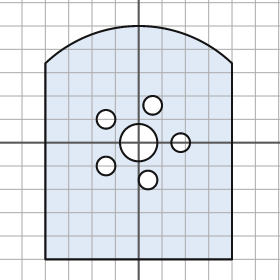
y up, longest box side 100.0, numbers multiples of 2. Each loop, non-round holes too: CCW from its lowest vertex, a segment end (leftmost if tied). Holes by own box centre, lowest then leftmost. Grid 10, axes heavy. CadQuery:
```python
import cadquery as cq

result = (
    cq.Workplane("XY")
    .moveTo(-40.0, -50.0)
    .lineTo(40.0, -50.0)
    .lineTo(40.0, 34.0)
    .threePointArc((0.0, 50.0), (-40.0, 34.0))
    .close()
    .moveTo(4.0, -16.0)
    .circle(4.0)
    .moveTo(-14.0, -10.0)
    .circle(4.0)
    .moveTo(0.0, 0.0)
    .circle(8.0)
    .moveTo(18.0, 0.0)
    .circle(4.0)
    .moveTo(-14.0, 10.0)
    .circle(4.0)
    .moveTo(6.0, 16.0)
    .circle(4.0)
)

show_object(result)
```